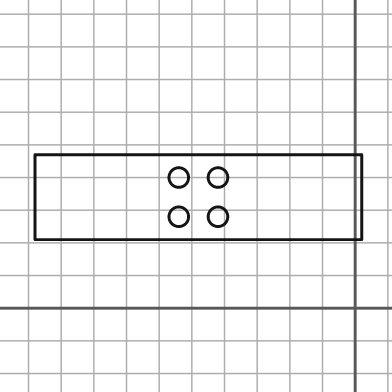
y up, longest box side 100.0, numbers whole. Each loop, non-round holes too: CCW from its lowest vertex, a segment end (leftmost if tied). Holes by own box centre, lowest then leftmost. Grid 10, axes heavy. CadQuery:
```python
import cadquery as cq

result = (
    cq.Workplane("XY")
    .moveTo(-98.0, 21.0)
    .lineTo(2.0, 21.0)
    .lineTo(2.0, 47.0)
    .lineTo(-98.0, 47.0)
    .close()
    .moveTo(-54.0, 28.0)
    .circle(3.0)
    .moveTo(-42.0, 28.0)
    .circle(3.0)
    .moveTo(-54.0, 40.0)
    .circle(3.0)
    .moveTo(-42.0, 40.0)
    .circle(3.0)
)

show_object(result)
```